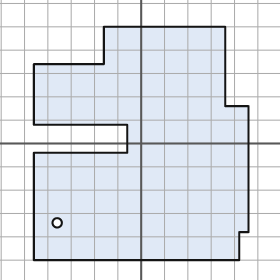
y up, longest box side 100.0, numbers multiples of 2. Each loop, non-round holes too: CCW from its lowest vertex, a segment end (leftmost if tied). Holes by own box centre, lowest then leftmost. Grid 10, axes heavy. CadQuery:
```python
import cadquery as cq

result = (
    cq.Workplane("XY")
    .moveTo(-46.0, -50.0)
    .lineTo(42.0, -50.0)
    .lineTo(42.0, -38.0)
    .lineTo(46.0, -38.0)
    .lineTo(46.0, 16.0)
    .lineTo(36.0, 16.0)
    .lineTo(36.0, 50.0)
    .lineTo(-16.0, 50.0)
    .lineTo(-16.0, 34.0)
    .lineTo(-46.0, 34.0)
    .lineTo(-46.0, 8.0)
    .lineTo(-6.0, 8.0)
    .lineTo(-6.0, -4.0)
    .lineTo(-46.0, -4.0)
    .close()
    .moveTo(-36.0, -34.0)
    .circle(2.0)
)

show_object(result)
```